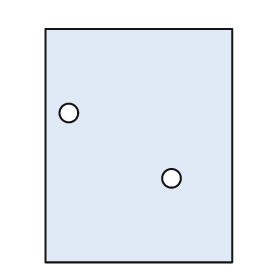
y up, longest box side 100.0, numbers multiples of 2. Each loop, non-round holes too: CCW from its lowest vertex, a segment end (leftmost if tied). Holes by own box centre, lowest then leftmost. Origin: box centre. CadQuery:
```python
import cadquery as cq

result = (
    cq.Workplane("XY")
    .moveTo(-40.0, -50.0)
    .lineTo(40.0, -50.0)
    .lineTo(40.0, 50.0)
    .lineTo(-40.0, 50.0)
    .close()
    .moveTo(14.0, -14.0)
    .circle(4.0)
    .moveTo(-30.0, 14.0)
    .circle(4.0)
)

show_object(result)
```